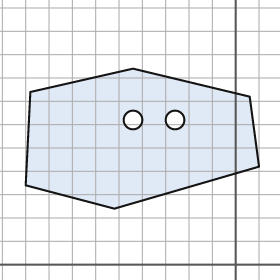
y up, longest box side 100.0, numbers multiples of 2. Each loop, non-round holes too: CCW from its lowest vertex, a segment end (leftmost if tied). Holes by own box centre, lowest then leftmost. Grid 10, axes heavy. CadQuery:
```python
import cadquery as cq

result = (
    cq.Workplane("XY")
    .moveTo(-52.0, 24.0)
    .lineTo(10.0, 42.0)
    .lineTo(6.0, 72.0)
    .lineTo(-44.0, 84.0)
    .lineTo(-88.0, 74.0)
    .lineTo(-90.0, 34.0)
    .close()
    .moveTo(-44.0, 62.0)
    .circle(4.0)
    .moveTo(-26.0, 62.0)
    .circle(4.0)
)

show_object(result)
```